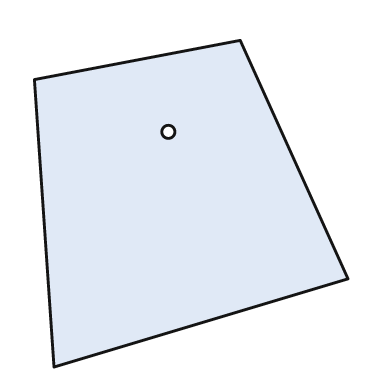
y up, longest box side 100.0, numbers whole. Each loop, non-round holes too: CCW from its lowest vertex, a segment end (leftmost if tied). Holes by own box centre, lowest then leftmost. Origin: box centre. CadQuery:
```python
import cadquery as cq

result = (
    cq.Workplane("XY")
    .moveTo(-42.0, -50.0)
    .lineTo(48.0, -23.0)
    .lineTo(15.0, 50.0)
    .lineTo(-48.0, 38.0)
    .close()
    .moveTo(-7.0, 22.0)
    .circle(2.0)
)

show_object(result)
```